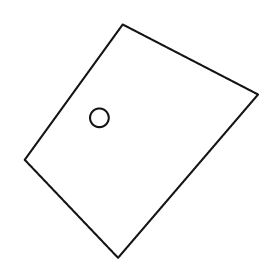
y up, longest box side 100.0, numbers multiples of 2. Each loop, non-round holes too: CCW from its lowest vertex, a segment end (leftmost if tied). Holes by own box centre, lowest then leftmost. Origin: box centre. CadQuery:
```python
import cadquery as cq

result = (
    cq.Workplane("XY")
    .moveTo(-10.0, -50.0)
    .lineTo(50.0, 20.0)
    .lineTo(-8.0, 50.0)
    .lineTo(-50.0, -8.0)
    .close()
    .moveTo(-18.0, 10.0)
    .circle(4.0)
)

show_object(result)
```